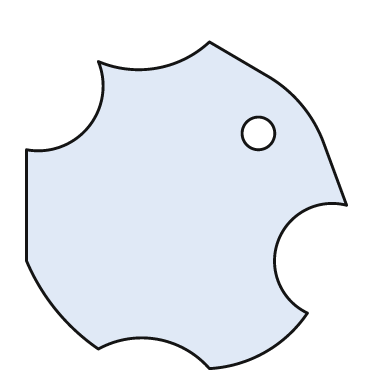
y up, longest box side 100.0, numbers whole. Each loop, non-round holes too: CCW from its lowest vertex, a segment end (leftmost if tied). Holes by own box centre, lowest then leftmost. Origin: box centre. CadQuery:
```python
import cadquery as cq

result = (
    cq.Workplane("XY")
    .moveTo(7.0, -50.0)
    .threePointArc((24.0, -45.0), (37.0, -33.0))
    .threePointArc((28.0, -11.0), (49.0, 0.0))
    .lineTo(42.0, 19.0)
    .threePointArc((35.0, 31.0), (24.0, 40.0))
    .lineTo(7.0, 50.0)
    .threePointArc((-9.0, 42.0), (-27.0, 44.0))
    .threePointArc((-30.0, 24.0), (-49.0, 17.0))
    .lineTo(-49.0, -17.0)
    .threePointArc((-40.0, -32.0), (-27.0, -44.0))
    .threePointArc((-9.0, -41.0), (7.0, -50.0))
    .close()
    .moveTo(22.0, 22.0)
    .circle(5.0)
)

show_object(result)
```